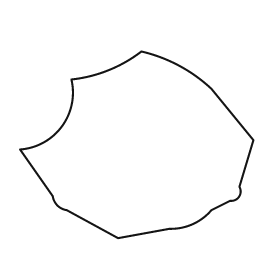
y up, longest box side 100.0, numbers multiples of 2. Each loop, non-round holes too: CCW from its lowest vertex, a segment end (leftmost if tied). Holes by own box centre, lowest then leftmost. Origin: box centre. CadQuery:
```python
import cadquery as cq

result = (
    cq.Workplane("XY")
    .moveTo(-8.0, -40.0)
    .lineTo(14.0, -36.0)
    .threePointArc((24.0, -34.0), (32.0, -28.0))
    .lineTo(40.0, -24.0)
    .threePointArc((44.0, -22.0), (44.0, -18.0))
    .lineTo(50.0, 2.0)
    .lineTo(32.0, 24.0)
    .threePointArc((18.0, 34.0), (2.0, 40.0))
    .threePointArc((-12.0, 32.0), (-28.0, 28.0))
    .threePointArc((-32.0, 8.0), (-50.0, -2.0))
    .lineTo(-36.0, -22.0)
    .threePointArc((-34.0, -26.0), (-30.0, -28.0))
    .close()
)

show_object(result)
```